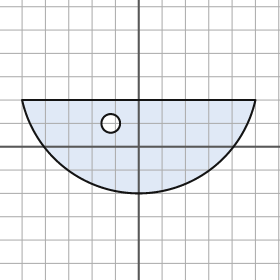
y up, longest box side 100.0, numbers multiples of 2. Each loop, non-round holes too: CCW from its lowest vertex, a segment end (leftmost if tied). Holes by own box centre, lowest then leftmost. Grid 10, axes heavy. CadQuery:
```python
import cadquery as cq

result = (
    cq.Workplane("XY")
    .moveTo(-50.0, 20.0)
    .threePointArc((0.0, -20.0), (50.0, 20.0))
    .close()
    .moveTo(-12.0, 10.0)
    .circle(4.0)
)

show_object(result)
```